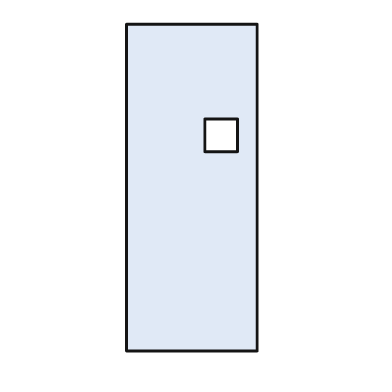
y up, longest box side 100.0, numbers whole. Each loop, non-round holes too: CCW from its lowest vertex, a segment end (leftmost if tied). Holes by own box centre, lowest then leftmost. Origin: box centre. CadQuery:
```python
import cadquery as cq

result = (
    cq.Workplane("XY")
    .moveTo(-20.0, -50.0)
    .lineTo(20.0, -50.0)
    .lineTo(20.0, 50.0)
    .lineTo(-20.0, 50.0)
    .close()
    .moveTo(4.0, 11.0)
    .lineTo(14.0, 11.0)
    .lineTo(14.0, 21.0)
    .lineTo(4.0, 21.0)
    .close()
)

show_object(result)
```